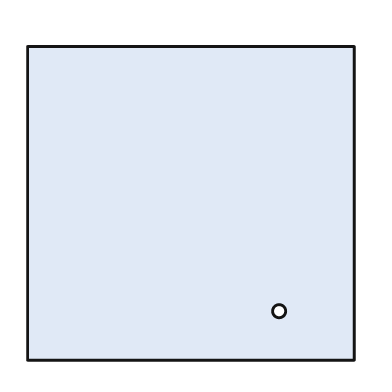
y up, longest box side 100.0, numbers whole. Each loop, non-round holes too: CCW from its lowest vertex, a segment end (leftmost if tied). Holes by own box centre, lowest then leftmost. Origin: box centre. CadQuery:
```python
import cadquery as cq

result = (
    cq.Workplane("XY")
    .moveTo(-50.0, -48.0)
    .lineTo(50.0, -48.0)
    .lineTo(50.0, 48.0)
    .lineTo(-50.0, 48.0)
    .close()
    .moveTo(27.0, -33.0)
    .circle(2.0)
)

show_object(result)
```